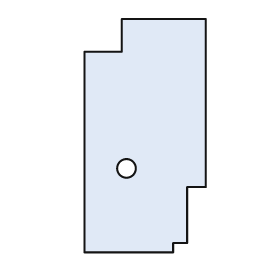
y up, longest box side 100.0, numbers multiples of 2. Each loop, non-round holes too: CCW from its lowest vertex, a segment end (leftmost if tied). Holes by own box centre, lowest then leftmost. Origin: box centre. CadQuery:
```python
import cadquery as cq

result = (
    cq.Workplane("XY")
    .moveTo(-26.0, -50.0)
    .lineTo(12.0, -50.0)
    .lineTo(12.0, -46.0)
    .lineTo(18.0, -46.0)
    .lineTo(18.0, -22.0)
    .lineTo(26.0, -22.0)
    .lineTo(26.0, 50.0)
    .lineTo(-10.0, 50.0)
    .lineTo(-10.0, 36.0)
    .lineTo(-26.0, 36.0)
    .close()
    .moveTo(-8.0, -14.0)
    .circle(4.0)
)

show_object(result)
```